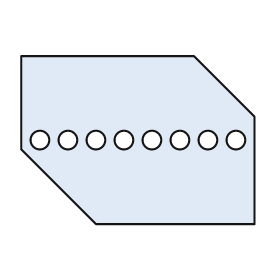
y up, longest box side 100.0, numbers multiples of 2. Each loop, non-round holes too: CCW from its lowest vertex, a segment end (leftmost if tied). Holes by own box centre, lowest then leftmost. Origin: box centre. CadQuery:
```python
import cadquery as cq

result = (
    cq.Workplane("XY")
    .moveTo(-18.0, -36.0)
    .lineTo(50.0, -36.0)
    .lineTo(50.0, 10.0)
    .lineTo(24.0, 36.0)
    .lineTo(-50.0, 36.0)
    .lineTo(-50.0, -4.0)
    .close()
    .moveTo(-42.0, 0.0)
    .circle(4.0)
    .moveTo(-30.0, 0.0)
    .circle(4.0)
    .moveTo(-18.0, 0.0)
    .circle(4.0)
    .moveTo(-6.0, 0.0)
    .circle(4.0)
    .moveTo(6.0, 0.0)
    .circle(4.0)
    .moveTo(18.0, 0.0)
    .circle(4.0)
    .moveTo(30.0, 0.0)
    .circle(4.0)
    .moveTo(42.0, 0.0)
    .circle(4.0)
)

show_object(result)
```